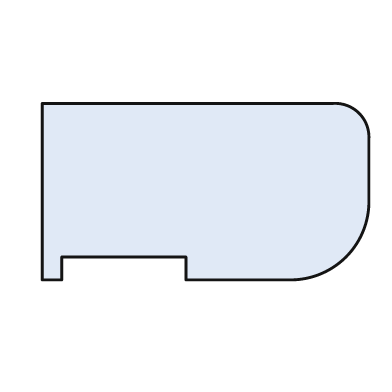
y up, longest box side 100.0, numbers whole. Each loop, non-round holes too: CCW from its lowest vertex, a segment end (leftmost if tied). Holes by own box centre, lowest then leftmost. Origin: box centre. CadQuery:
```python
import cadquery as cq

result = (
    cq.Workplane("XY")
    .moveTo(-50.0, -27.0)
    .lineTo(-44.0, -27.0)
    .lineTo(-44.0, -20.0)
    .lineTo(-6.0, -20.0)
    .lineTo(-6.0, -27.0)
    .lineTo(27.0, -27.0)
    .threePointArc((43.0, -20.0), (50.0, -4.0))
    .lineTo(50.0, 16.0)
    .threePointArc((47.0, 24.0), (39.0, 27.0))
    .lineTo(-50.0, 27.0)
    .close()
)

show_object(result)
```